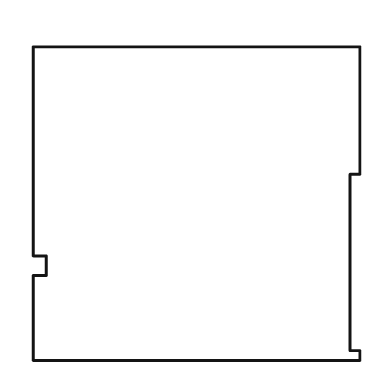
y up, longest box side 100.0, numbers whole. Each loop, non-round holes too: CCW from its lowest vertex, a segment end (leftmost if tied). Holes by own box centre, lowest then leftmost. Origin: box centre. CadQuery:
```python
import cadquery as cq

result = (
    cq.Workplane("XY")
    .moveTo(-50.0, -48.0)
    .lineTo(50.0, -48.0)
    .lineTo(50.0, -45.0)
    .lineTo(47.0, -45.0)
    .lineTo(47.0, 9.0)
    .lineTo(50.0, 9.0)
    .lineTo(50.0, 48.0)
    .lineTo(-50.0, 48.0)
    .lineTo(-50.0, -16.0)
    .lineTo(-46.0, -16.0)
    .lineTo(-46.0, -22.0)
    .lineTo(-50.0, -22.0)
    .close()
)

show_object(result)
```